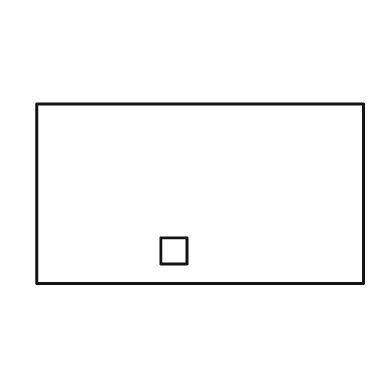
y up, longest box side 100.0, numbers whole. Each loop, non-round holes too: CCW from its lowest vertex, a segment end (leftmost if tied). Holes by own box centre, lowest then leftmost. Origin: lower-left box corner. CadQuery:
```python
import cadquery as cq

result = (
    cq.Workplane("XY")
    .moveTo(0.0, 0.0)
    .lineTo(100.0, 0.0)
    .lineTo(100.0, 55.0)
    .lineTo(0.0, 55.0)
    .close()
    .moveTo(38.0, 6.0)
    .lineTo(46.0, 6.0)
    .lineTo(46.0, 14.0)
    .lineTo(38.0, 14.0)
    .close()
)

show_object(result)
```